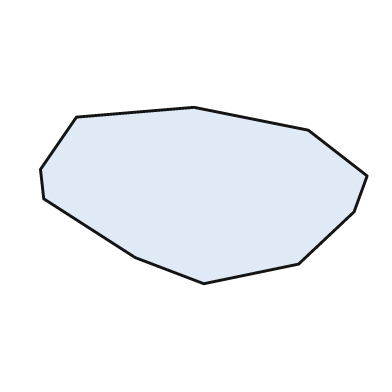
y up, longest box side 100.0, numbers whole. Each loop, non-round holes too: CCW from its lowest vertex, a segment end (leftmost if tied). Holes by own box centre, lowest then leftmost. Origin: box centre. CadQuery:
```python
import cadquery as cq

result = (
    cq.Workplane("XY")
    .moveTo(0.0, -27.0)
    .lineTo(29.0, -21.0)
    .lineTo(46.0, -5.0)
    .lineTo(50.0, 6.0)
    .lineTo(32.0, 20.0)
    .lineTo(-3.0, 27.0)
    .lineTo(-39.0, 24.0)
    .lineTo(-50.0, 8.0)
    .lineTo(-49.0, -1.0)
    .lineTo(-21.0, -19.0)
    .close()
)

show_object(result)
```